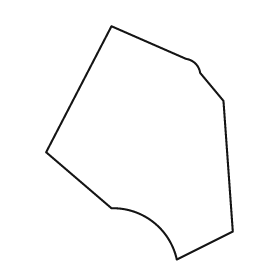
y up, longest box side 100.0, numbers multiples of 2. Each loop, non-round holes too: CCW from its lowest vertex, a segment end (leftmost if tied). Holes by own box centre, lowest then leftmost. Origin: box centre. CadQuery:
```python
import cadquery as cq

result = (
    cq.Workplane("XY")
    .moveTo(16.0, -50.0)
    .lineTo(40.0, -38.0)
    .lineTo(36.0, 18.0)
    .lineTo(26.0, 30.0)
    .threePointArc((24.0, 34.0), (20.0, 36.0))
    .lineTo(-12.0, 50.0)
    .lineTo(-40.0, -4.0)
    .lineTo(-12.0, -28.0)
    .threePointArc((6.0, -34.0), (16.0, -50.0))
    .close()
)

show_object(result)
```